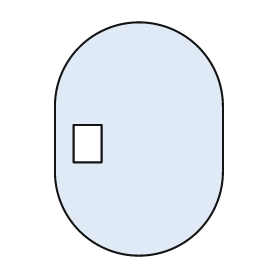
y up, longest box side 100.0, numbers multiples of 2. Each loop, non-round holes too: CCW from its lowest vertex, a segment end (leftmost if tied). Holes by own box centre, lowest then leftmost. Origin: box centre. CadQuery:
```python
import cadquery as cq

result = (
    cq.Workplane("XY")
    .moveTo(-36.0, -14.0)
    .threePointArc((0.0, -50.0), (36.0, -14.0))
    .lineTo(36.0, 14.0)
    .threePointArc((0.0, 50.0), (-36.0, 14.0))
    .close()
    .moveTo(-28.0, -10.0)
    .lineTo(-16.0, -10.0)
    .lineTo(-16.0, 6.0)
    .lineTo(-28.0, 6.0)
    .close()
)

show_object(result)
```